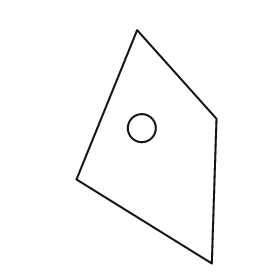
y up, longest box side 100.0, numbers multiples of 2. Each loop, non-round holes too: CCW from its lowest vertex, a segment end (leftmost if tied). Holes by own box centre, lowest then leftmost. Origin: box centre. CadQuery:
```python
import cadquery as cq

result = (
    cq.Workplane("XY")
    .moveTo(28.0, -50.0)
    .lineTo(30.0, 12.0)
    .lineTo(-4.0, 50.0)
    .lineTo(-30.0, -14.0)
    .close()
    .moveTo(-2.0, 8.0)
    .circle(6.0)
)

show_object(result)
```